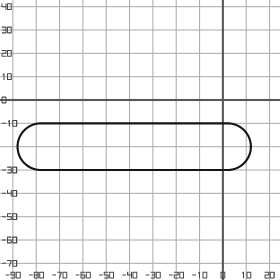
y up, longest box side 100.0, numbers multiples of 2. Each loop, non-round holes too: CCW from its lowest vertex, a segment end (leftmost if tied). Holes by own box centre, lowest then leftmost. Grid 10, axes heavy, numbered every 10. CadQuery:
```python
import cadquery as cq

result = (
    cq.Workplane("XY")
    .moveTo(-78.0, -30.0)
    .lineTo(2.0, -30.0)
    .threePointArc((12.0, -20.0), (2.0, -10.0))
    .lineTo(-78.0, -10.0)
    .threePointArc((-88.0, -20.0), (-78.0, -30.0))
    .close()
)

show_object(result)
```